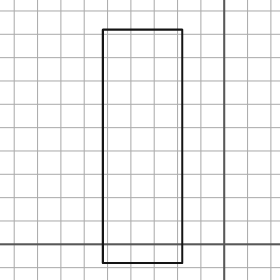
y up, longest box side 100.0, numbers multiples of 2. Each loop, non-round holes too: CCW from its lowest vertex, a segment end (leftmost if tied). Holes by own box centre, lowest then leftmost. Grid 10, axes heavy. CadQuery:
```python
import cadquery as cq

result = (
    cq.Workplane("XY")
    .moveTo(-52.0, -8.0)
    .lineTo(-18.0, -8.0)
    .lineTo(-18.0, 92.0)
    .lineTo(-52.0, 92.0)
    .close()
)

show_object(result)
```